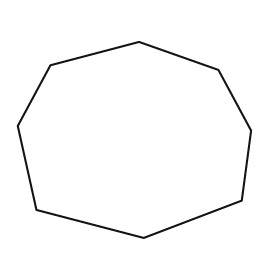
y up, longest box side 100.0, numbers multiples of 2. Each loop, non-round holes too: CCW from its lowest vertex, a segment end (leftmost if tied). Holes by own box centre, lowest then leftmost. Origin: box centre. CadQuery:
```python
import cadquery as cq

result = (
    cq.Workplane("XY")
    .moveTo(4.0, -42.0)
    .lineTo(46.0, -26.0)
    .lineTo(50.0, 4.0)
    .lineTo(36.0, 30.0)
    .lineTo(2.0, 42.0)
    .lineTo(-36.0, 32.0)
    .lineTo(-50.0, 6.0)
    .lineTo(-42.0, -30.0)
    .close()
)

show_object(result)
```